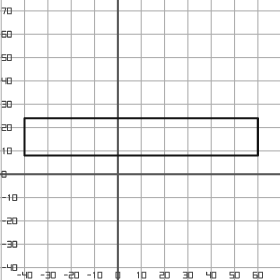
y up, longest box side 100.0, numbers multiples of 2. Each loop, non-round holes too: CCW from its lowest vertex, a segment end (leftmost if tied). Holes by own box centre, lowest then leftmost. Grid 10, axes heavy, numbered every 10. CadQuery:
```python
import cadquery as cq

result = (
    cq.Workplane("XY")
    .moveTo(-40.0, 8.0)
    .lineTo(60.0, 8.0)
    .lineTo(60.0, 24.0)
    .lineTo(-40.0, 24.0)
    .close()
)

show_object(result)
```